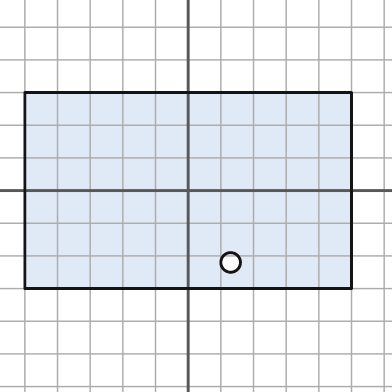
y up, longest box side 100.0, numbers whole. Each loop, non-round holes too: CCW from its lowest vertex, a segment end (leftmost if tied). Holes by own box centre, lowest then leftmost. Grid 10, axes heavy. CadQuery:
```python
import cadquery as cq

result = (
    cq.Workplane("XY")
    .moveTo(-50.0, -30.0)
    .lineTo(50.0, -30.0)
    .lineTo(50.0, 30.0)
    .lineTo(-50.0, 30.0)
    .close()
    .moveTo(13.0, -22.0)
    .circle(3.0)
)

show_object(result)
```